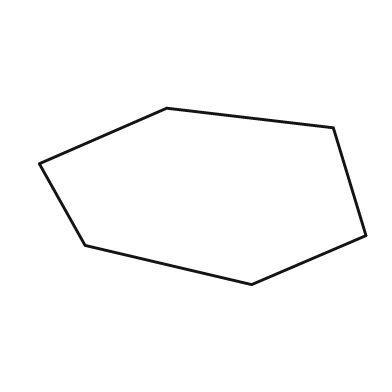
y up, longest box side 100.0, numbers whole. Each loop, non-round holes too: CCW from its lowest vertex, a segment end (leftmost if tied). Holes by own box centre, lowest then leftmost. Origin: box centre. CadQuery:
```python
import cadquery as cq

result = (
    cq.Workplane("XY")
    .moveTo(15.0, -27.0)
    .lineTo(50.0, -12.0)
    .lineTo(40.0, 21.0)
    .lineTo(-11.0, 27.0)
    .lineTo(-50.0, 10.0)
    .lineTo(-36.0, -15.0)
    .close()
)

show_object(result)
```